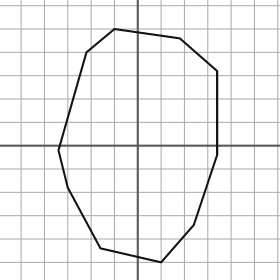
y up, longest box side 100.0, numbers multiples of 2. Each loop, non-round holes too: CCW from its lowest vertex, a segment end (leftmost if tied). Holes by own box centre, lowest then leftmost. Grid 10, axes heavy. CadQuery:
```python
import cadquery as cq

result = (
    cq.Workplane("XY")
    .moveTo(10.0, -50.0)
    .lineTo(24.0, -34.0)
    .lineTo(34.0, -4.0)
    .lineTo(34.0, 32.0)
    .lineTo(18.0, 46.0)
    .lineTo(-10.0, 50.0)
    .lineTo(-22.0, 40.0)
    .lineTo(-34.0, -2.0)
    .lineTo(-30.0, -18.0)
    .lineTo(-16.0, -44.0)
    .close()
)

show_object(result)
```